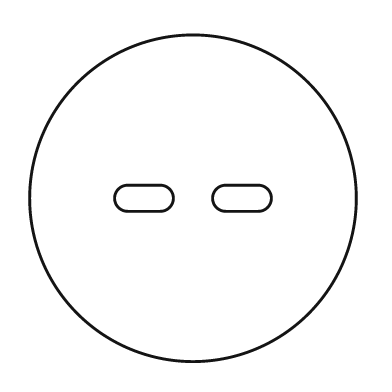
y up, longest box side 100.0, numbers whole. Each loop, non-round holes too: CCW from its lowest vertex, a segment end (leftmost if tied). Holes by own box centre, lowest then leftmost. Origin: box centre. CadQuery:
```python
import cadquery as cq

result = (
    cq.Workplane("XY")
    .moveTo(0.0, 0.0)
    .circle(50.0)
    .moveTo(-20.0, -4.0)
    .lineTo(-10.0, -4.0)
    .threePointArc((-6.0, 0.0), (-10.0, 4.0))
    .lineTo(-20.0, 4.0)
    .threePointArc((-24.0, 0.0), (-20.0, -4.0))
    .close()
    .moveTo(10.0, -4.0)
    .lineTo(20.0, -4.0)
    .threePointArc((24.0, 0.0), (20.0, 4.0))
    .lineTo(10.0, 4.0)
    .threePointArc((6.0, 0.0), (10.0, -4.0))
    .close()
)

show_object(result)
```